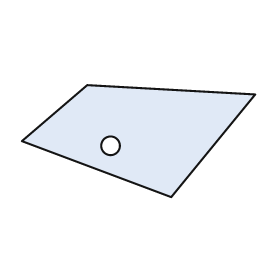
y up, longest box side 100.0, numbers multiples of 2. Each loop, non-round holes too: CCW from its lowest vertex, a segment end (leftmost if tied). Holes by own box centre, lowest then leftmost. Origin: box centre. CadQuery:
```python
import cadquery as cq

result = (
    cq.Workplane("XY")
    .moveTo(14.0, -24.0)
    .lineTo(50.0, 20.0)
    .lineTo(-22.0, 24.0)
    .lineTo(-50.0, 0.0)
    .close()
    .moveTo(-12.0, -2.0)
    .circle(4.0)
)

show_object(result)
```